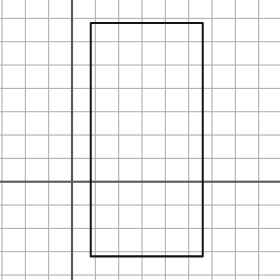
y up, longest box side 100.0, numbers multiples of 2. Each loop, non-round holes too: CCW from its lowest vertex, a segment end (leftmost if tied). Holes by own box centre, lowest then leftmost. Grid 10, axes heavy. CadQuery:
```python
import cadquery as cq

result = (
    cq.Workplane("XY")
    .moveTo(8.0, -32.0)
    .lineTo(56.0, -32.0)
    .lineTo(56.0, 68.0)
    .lineTo(8.0, 68.0)
    .close()
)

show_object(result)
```